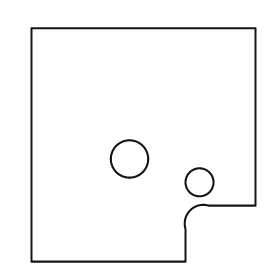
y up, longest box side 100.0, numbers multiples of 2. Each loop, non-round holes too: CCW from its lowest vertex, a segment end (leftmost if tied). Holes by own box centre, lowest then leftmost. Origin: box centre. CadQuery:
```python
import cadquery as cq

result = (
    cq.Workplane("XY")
    .moveTo(-48.0, -50.0)
    .lineTo(18.0, -50.0)
    .lineTo(18.0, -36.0)
    .threePointArc((20.0, -28.0), (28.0, -26.0))
    .lineTo(48.0, -26.0)
    .lineTo(48.0, 50.0)
    .lineTo(-48.0, 50.0)
    .close()
    .moveTo(24.0, -16.0)
    .circle(6.0)
    .moveTo(-6.0, -6.0)
    .circle(8.0)
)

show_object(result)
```